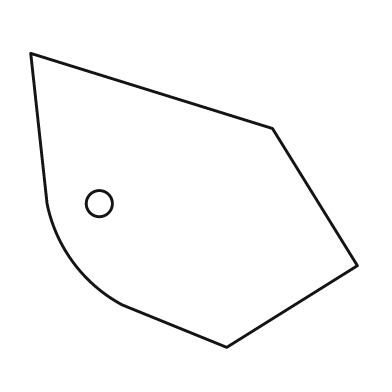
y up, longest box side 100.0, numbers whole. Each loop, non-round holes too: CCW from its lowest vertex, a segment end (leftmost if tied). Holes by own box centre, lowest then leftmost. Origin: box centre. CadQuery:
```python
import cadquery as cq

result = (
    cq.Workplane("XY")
    .moveTo(10.0, -45.0)
    .lineTo(50.0, -20.0)
    .lineTo(24.0, 22.0)
    .lineTo(-50.0, 45.0)
    .lineTo(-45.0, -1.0)
    .threePointArc((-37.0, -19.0), (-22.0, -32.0))
    .close()
    .moveTo(-29.0, -1.0)
    .circle(4.0)
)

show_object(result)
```